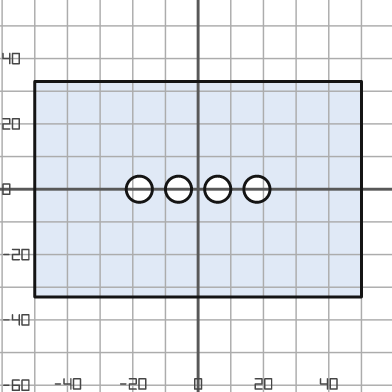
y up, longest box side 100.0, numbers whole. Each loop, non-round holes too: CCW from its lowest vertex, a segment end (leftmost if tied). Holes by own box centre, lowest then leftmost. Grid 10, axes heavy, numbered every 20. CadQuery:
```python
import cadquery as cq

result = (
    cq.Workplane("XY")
    .moveTo(-50.0, -33.0)
    .lineTo(50.0, -33.0)
    .lineTo(50.0, 33.0)
    .lineTo(-50.0, 33.0)
    .close()
    .moveTo(-18.0, 0.0)
    .circle(4.0)
    .moveTo(-6.0, 0.0)
    .circle(4.0)
    .moveTo(6.0, 0.0)
    .circle(4.0)
    .moveTo(18.0, 0.0)
    .circle(4.0)
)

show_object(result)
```